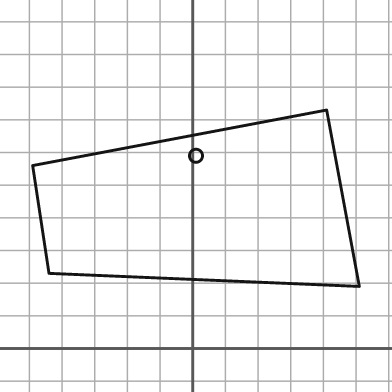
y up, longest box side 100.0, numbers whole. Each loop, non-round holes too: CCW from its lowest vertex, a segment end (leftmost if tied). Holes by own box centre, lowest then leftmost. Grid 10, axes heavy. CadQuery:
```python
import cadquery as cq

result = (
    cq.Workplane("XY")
    .moveTo(51.0, 19.0)
    .lineTo(41.0, 73.0)
    .lineTo(-49.0, 56.0)
    .lineTo(-44.0, 23.0)
    .close()
    .moveTo(1.0, 59.0)
    .circle(2.0)
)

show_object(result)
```